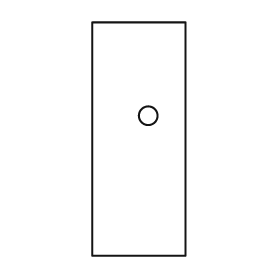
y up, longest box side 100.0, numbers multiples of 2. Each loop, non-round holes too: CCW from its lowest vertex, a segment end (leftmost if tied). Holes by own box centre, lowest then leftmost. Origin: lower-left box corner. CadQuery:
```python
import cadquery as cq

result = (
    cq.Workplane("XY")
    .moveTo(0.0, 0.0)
    .lineTo(40.0, 0.0)
    .lineTo(40.0, 100.0)
    .lineTo(0.0, 100.0)
    .close()
    .moveTo(24.0, 60.0)
    .circle(4.0)
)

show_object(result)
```